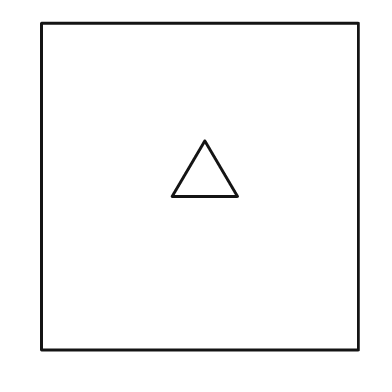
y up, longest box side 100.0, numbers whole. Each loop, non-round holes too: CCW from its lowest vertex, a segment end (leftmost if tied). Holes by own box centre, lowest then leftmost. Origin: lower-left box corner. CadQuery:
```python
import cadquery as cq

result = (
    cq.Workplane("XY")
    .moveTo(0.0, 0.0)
    .lineTo(97.0, 0.0)
    .lineTo(97.0, 100.0)
    .lineTo(0.0, 100.0)
    .close()
    .moveTo(40.0, 47.0)
    .lineTo(60.0, 47.0)
    .lineTo(50.0, 64.0)
    .close()
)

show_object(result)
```